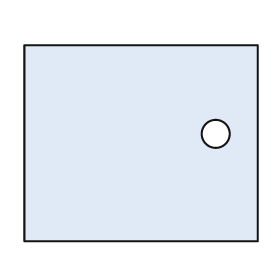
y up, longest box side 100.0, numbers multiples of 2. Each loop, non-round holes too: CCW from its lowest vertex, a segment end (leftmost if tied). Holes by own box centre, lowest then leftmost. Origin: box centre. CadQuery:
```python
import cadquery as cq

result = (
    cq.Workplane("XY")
    .moveTo(-50.0, -42.0)
    .lineTo(50.0, -42.0)
    .lineTo(50.0, 42.0)
    .lineTo(-50.0, 42.0)
    .close()
    .moveTo(32.0, 4.0)
    .circle(6.0)
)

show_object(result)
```